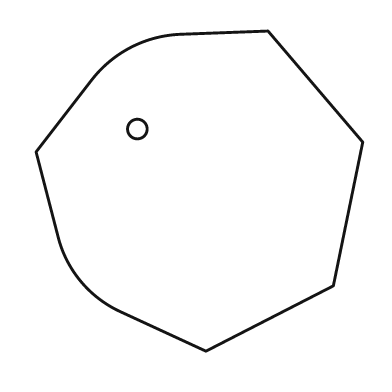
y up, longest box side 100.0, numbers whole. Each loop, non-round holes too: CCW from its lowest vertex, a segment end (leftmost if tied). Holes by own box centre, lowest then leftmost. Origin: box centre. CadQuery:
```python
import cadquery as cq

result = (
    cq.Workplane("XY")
    .moveTo(2.0, -49.0)
    .lineTo(41.0, -29.0)
    .lineTo(50.0, 15.0)
    .lineTo(21.0, 49.0)
    .lineTo(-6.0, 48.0)
    .threePointArc((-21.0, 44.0), (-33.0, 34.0))
    .lineTo(-50.0, 12.0)
    .lineTo(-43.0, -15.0)
    .threePointArc((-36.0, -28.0), (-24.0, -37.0))
    .close()
    .moveTo(-19.0, 19.0)
    .circle(3.0)
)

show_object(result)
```